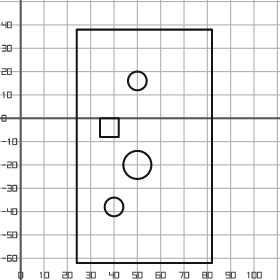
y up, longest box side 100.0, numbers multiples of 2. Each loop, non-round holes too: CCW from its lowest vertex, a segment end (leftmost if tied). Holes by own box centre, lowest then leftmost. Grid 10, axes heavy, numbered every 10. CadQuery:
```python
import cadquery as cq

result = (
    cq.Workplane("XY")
    .moveTo(24.0, -62.0)
    .lineTo(82.0, -62.0)
    .lineTo(82.0, 38.0)
    .lineTo(24.0, 38.0)
    .close()
    .moveTo(40.0, -38.0)
    .circle(4.0)
    .moveTo(50.0, -20.0)
    .circle(6.0)
    .moveTo(34.0, -8.0)
    .lineTo(42.0, -8.0)
    .lineTo(42.0, 0.0)
    .lineTo(34.0, 0.0)
    .close()
    .moveTo(50.0, 16.0)
    .circle(4.0)
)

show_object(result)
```